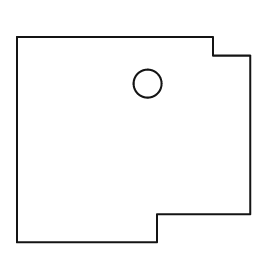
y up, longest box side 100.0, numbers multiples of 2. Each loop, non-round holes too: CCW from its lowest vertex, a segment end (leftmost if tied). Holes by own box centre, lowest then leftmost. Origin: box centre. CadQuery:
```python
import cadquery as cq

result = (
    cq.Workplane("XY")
    .moveTo(-50.0, -44.0)
    .lineTo(10.0, -44.0)
    .lineTo(10.0, -32.0)
    .lineTo(50.0, -32.0)
    .lineTo(50.0, 36.0)
    .lineTo(34.0, 36.0)
    .lineTo(34.0, 44.0)
    .lineTo(-50.0, 44.0)
    .close()
    .moveTo(6.0, 24.0)
    .circle(6.0)
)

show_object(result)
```